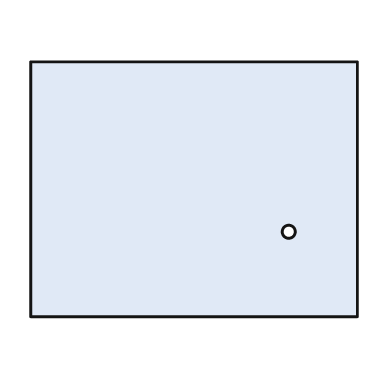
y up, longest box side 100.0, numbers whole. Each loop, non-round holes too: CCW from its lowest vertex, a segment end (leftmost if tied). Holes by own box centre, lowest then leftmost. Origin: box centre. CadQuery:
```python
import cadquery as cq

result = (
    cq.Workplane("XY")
    .moveTo(-50.0, -39.0)
    .lineTo(50.0, -39.0)
    .lineTo(50.0, 39.0)
    .lineTo(-50.0, 39.0)
    .close()
    .moveTo(29.0, -13.0)
    .circle(2.0)
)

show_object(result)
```